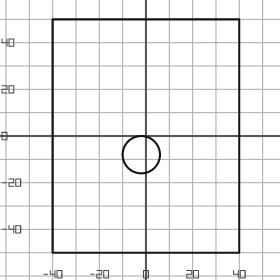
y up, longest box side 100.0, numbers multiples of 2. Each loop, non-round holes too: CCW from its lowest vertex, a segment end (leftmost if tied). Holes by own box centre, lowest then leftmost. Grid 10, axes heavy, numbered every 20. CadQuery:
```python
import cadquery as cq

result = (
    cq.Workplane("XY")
    .moveTo(-40.0, -50.0)
    .lineTo(40.0, -50.0)
    .lineTo(40.0, 50.0)
    .lineTo(-40.0, 50.0)
    .close()
    .moveTo(-2.0, -8.0)
    .circle(8.0)
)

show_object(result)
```